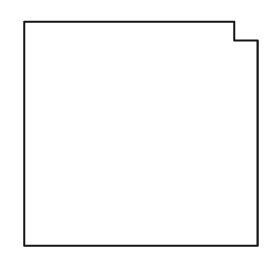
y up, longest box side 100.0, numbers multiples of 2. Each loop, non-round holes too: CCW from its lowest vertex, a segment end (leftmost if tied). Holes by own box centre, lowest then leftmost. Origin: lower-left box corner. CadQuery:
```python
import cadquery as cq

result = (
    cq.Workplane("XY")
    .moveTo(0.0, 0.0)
    .lineTo(100.0, 0.0)
    .lineTo(100.0, 88.0)
    .lineTo(90.0, 88.0)
    .lineTo(90.0, 96.0)
    .lineTo(0.0, 96.0)
    .close()
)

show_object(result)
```